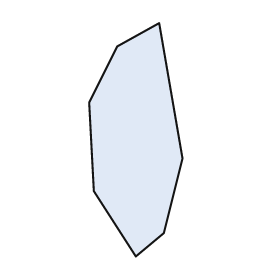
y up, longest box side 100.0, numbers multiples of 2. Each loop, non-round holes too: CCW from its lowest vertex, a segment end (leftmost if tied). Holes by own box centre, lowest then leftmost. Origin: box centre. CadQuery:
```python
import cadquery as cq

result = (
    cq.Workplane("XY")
    .moveTo(0.0, -50.0)
    .lineTo(12.0, -40.0)
    .lineTo(20.0, -8.0)
    .lineTo(10.0, 50.0)
    .lineTo(-8.0, 40.0)
    .lineTo(-20.0, 16.0)
    .lineTo(-18.0, -22.0)
    .close()
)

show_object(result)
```